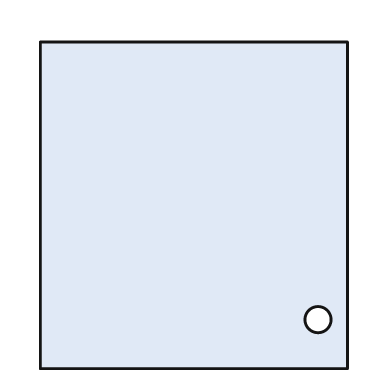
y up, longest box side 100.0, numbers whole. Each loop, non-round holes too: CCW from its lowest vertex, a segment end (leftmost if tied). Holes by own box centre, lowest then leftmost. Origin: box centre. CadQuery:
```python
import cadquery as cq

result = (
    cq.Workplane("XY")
    .moveTo(-47.0, -50.0)
    .lineTo(47.0, -50.0)
    .lineTo(47.0, 50.0)
    .lineTo(-47.0, 50.0)
    .close()
    .moveTo(38.0, -35.0)
    .circle(4.0)
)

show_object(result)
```